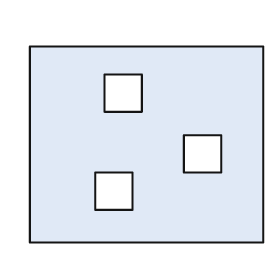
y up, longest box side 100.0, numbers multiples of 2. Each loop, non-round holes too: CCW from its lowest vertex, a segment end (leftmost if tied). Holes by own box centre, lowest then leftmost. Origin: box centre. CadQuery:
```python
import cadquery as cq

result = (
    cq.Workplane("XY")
    .moveTo(-50.0, -42.0)
    .lineTo(50.0, -42.0)
    .lineTo(50.0, 42.0)
    .lineTo(-50.0, 42.0)
    .close()
    .moveTo(-22.0, -28.0)
    .lineTo(-6.0, -28.0)
    .lineTo(-6.0, -12.0)
    .lineTo(-22.0, -12.0)
    .close()
    .moveTo(16.0, -12.0)
    .lineTo(32.0, -12.0)
    .lineTo(32.0, 4.0)
    .lineTo(16.0, 4.0)
    .close()
    .moveTo(-18.0, 14.0)
    .lineTo(-2.0, 14.0)
    .lineTo(-2.0, 30.0)
    .lineTo(-18.0, 30.0)
    .close()
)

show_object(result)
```